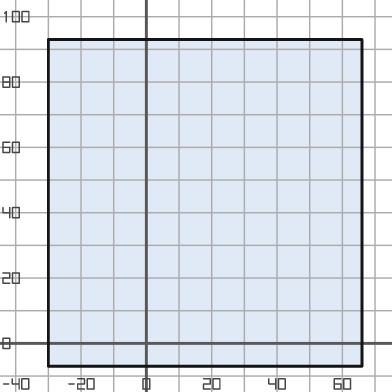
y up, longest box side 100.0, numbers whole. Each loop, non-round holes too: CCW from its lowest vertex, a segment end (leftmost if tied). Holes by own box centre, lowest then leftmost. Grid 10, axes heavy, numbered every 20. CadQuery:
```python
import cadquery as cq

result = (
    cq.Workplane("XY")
    .moveTo(-30.0, -7.0)
    .lineTo(66.0, -7.0)
    .lineTo(66.0, 93.0)
    .lineTo(-30.0, 93.0)
    .close()
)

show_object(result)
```